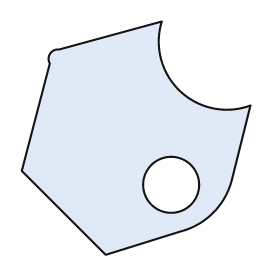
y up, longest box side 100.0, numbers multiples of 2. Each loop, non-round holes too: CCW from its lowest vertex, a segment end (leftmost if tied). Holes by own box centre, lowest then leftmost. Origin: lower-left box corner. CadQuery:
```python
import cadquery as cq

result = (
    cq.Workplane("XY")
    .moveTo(36.0, 0.0)
    .lineTo(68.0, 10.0)
    .threePointArc((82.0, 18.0), (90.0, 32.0))
    .lineTo(98.0, 64.0)
    .threePointArc((68.0, 70.0), (60.0, 100.0))
    .lineTo(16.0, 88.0)
    .threePointArc((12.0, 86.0), (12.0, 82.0))
    .lineTo(0.0, 36.0)
    .close()
    .moveTo(64.0, 30.0)
    .circle(12.0)
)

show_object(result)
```